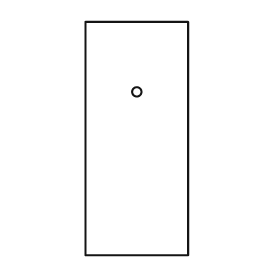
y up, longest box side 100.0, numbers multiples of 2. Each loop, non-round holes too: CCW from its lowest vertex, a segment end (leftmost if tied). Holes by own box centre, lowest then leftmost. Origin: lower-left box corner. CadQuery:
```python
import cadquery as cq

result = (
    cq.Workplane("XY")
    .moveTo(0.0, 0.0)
    .lineTo(44.0, 0.0)
    .lineTo(44.0, 100.0)
    .lineTo(0.0, 100.0)
    .close()
    .moveTo(22.0, 70.0)
    .circle(2.0)
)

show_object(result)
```